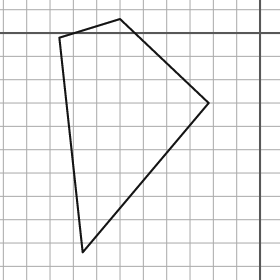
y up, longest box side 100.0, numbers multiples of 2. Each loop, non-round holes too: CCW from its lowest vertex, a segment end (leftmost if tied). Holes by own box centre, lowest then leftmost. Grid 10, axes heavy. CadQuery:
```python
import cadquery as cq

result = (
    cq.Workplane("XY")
    .moveTo(-76.0, -94.0)
    .lineTo(-22.0, -30.0)
    .lineTo(-60.0, 6.0)
    .lineTo(-86.0, -2.0)
    .close()
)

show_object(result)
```